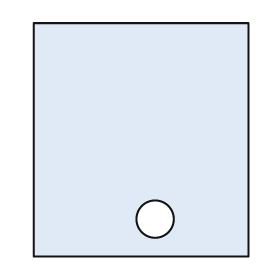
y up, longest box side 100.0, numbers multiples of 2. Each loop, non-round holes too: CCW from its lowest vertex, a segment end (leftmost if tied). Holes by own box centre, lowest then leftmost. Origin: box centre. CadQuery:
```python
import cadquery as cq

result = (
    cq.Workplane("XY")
    .moveTo(-46.0, -50.0)
    .lineTo(46.0, -50.0)
    .lineTo(46.0, 50.0)
    .lineTo(-46.0, 50.0)
    .close()
    .moveTo(6.0, -34.0)
    .circle(8.0)
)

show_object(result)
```